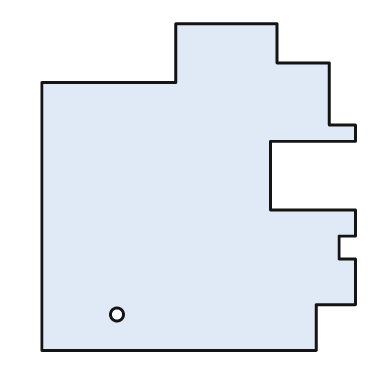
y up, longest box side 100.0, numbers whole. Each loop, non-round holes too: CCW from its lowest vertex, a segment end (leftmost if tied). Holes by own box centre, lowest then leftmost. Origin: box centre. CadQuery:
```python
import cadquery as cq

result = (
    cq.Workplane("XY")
    .moveTo(-48.0, -50.0)
    .lineTo(36.0, -50.0)
    .lineTo(36.0, -36.0)
    .lineTo(48.0, -36.0)
    .lineTo(48.0, -22.0)
    .lineTo(43.0, -22.0)
    .lineTo(43.0, -15.0)
    .lineTo(48.0, -15.0)
    .lineTo(48.0, -7.0)
    .lineTo(22.0, -7.0)
    .lineTo(22.0, 14.0)
    .lineTo(48.0, 14.0)
    .lineTo(48.0, 19.0)
    .lineTo(40.0, 19.0)
    .lineTo(40.0, 38.0)
    .lineTo(24.0, 38.0)
    .lineTo(24.0, 50.0)
    .lineTo(-7.0, 50.0)
    .lineTo(-7.0, 32.0)
    .lineTo(-48.0, 32.0)
    .close()
    .moveTo(-25.0, -39.0)
    .circle(2.0)
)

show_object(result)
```